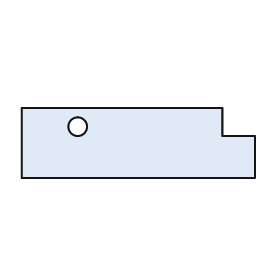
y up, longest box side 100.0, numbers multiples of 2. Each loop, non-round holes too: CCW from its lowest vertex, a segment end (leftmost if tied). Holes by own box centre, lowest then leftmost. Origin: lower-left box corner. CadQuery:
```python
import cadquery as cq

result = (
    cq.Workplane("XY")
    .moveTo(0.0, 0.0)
    .lineTo(100.0, 0.0)
    .lineTo(100.0, 18.0)
    .lineTo(86.0, 18.0)
    .lineTo(86.0, 30.0)
    .lineTo(0.0, 30.0)
    .close()
    .moveTo(24.0, 22.0)
    .circle(4.0)
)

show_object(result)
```